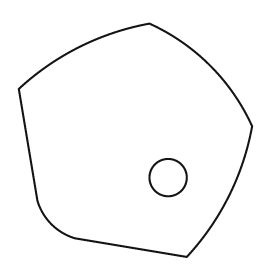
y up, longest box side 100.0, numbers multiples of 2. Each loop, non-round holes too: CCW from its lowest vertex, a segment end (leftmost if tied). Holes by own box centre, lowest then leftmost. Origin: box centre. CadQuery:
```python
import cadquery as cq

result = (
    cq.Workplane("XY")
    .moveTo(22.0, -50.0)
    .threePointArc((40.0, -24.0), (50.0, 6.0))
    .threePointArc((32.0, 32.0), (6.0, 50.0))
    .threePointArc((-24.0, 40.0), (-50.0, 22.0))
    .lineTo(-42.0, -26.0)
    .threePointArc((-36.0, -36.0), (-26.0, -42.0))
    .close()
    .moveTo(14.0, -16.0)
    .circle(8.0)
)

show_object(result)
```